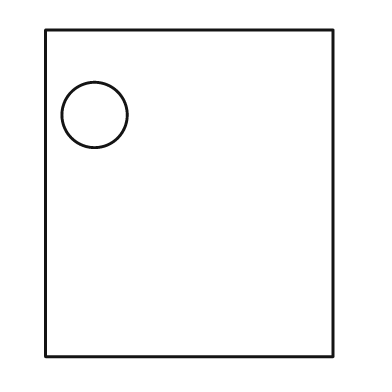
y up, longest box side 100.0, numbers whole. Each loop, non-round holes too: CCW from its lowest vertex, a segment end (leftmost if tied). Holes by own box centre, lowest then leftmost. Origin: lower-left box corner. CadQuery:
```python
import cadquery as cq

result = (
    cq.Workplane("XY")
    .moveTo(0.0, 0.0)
    .lineTo(88.0, 0.0)
    .lineTo(88.0, 100.0)
    .lineTo(0.0, 100.0)
    .close()
    .moveTo(15.0, 74.0)
    .circle(10.0)
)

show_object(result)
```